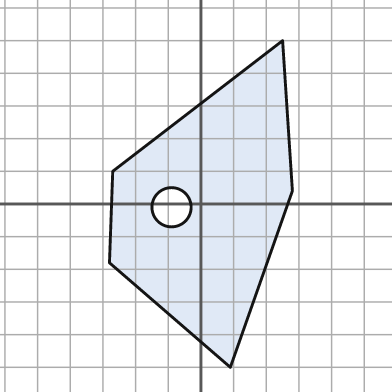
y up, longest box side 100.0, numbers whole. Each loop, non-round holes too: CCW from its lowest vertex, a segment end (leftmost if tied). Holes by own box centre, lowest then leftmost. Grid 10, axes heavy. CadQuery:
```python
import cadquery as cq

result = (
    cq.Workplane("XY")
    .moveTo(9.0, -50.0)
    .lineTo(28.0, 4.0)
    .lineTo(25.0, 50.0)
    .lineTo(-27.0, 10.0)
    .lineTo(-28.0, -18.0)
    .close()
    .moveTo(-9.0, -1.0)
    .circle(6.0)
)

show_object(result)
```